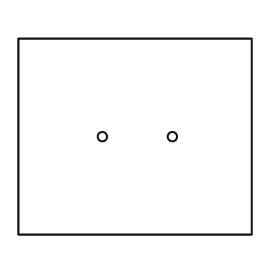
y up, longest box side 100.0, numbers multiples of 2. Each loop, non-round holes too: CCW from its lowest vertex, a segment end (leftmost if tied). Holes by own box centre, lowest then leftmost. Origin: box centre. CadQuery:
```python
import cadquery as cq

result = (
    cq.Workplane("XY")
    .moveTo(-50.0, -42.0)
    .lineTo(50.0, -42.0)
    .lineTo(50.0, 42.0)
    .lineTo(-50.0, 42.0)
    .close()
    .moveTo(-14.0, 0.0)
    .circle(2.0)
    .moveTo(16.0, 0.0)
    .circle(2.0)
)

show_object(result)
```